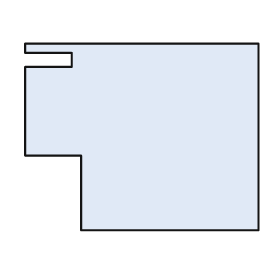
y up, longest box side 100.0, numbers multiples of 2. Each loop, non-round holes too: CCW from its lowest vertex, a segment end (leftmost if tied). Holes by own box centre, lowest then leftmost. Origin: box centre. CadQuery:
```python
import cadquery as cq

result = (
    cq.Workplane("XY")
    .moveTo(-26.0, -40.0)
    .lineTo(50.0, -40.0)
    .lineTo(50.0, 40.0)
    .lineTo(-50.0, 40.0)
    .lineTo(-50.0, 36.0)
    .lineTo(-30.0, 36.0)
    .lineTo(-30.0, 30.0)
    .lineTo(-50.0, 30.0)
    .lineTo(-50.0, -8.0)
    .lineTo(-26.0, -8.0)
    .close()
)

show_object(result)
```